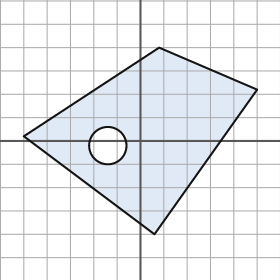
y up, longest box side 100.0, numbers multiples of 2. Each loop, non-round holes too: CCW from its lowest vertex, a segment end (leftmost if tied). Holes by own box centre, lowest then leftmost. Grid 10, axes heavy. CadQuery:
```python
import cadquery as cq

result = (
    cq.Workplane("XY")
    .moveTo(6.0, -40.0)
    .lineTo(50.0, 22.0)
    .lineTo(8.0, 40.0)
    .lineTo(-50.0, 2.0)
    .close()
    .moveTo(-14.0, -2.0)
    .circle(8.0)
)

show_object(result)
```